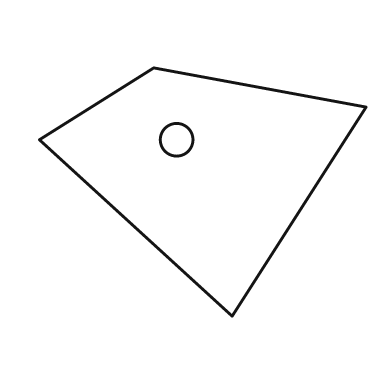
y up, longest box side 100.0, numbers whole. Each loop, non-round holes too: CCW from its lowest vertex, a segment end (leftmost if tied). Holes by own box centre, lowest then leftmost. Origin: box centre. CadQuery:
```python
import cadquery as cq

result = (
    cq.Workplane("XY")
    .moveTo(9.0, -38.0)
    .lineTo(50.0, 26.0)
    .lineTo(-15.0, 38.0)
    .lineTo(-50.0, 16.0)
    .close()
    .moveTo(-8.0, 16.0)
    .circle(5.0)
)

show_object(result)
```